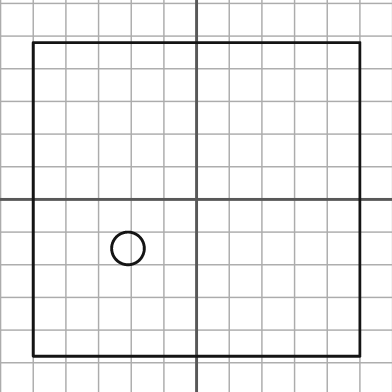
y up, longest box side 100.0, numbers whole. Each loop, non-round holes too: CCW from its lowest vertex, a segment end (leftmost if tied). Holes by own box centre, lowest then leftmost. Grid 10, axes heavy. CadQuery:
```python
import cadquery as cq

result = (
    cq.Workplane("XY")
    .moveTo(-50.0, -48.0)
    .lineTo(50.0, -48.0)
    .lineTo(50.0, 48.0)
    .lineTo(-50.0, 48.0)
    .close()
    .moveTo(-21.0, -15.0)
    .circle(5.0)
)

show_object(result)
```